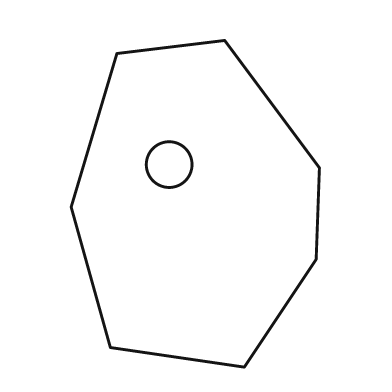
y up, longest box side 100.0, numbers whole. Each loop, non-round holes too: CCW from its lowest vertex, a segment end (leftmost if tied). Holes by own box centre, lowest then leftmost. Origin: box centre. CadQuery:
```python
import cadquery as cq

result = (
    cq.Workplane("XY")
    .moveTo(15.0, -50.0)
    .lineTo(37.0, -17.0)
    .lineTo(38.0, 11.0)
    .lineTo(9.0, 50.0)
    .lineTo(-24.0, 46.0)
    .lineTo(-38.0, -1.0)
    .lineTo(-26.0, -44.0)
    .close()
    .moveTo(-8.0, 12.0)
    .circle(7.0)
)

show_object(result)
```